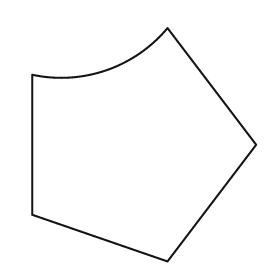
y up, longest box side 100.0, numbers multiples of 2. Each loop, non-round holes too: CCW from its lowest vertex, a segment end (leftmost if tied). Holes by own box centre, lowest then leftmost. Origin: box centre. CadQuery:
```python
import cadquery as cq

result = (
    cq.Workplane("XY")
    .moveTo(10.0, -50.0)
    .lineTo(48.0, 0.0)
    .lineTo(10.0, 50.0)
    .threePointArc((-16.0, 32.0), (-48.0, 30.0))
    .lineTo(-48.0, -30.0)
    .close()
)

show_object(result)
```